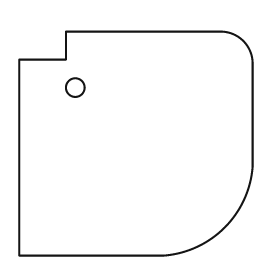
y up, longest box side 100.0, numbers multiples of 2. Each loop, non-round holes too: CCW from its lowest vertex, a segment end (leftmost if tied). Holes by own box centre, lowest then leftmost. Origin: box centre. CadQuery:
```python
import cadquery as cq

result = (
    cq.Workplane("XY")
    .moveTo(-50.0, -48.0)
    .lineTo(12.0, -48.0)
    .threePointArc((38.0, -36.0), (50.0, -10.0))
    .lineTo(50.0, 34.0)
    .threePointArc((46.0, 44.0), (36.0, 48.0))
    .lineTo(-30.0, 48.0)
    .lineTo(-30.0, 36.0)
    .lineTo(-50.0, 36.0)
    .close()
    .moveTo(-26.0, 24.0)
    .circle(4.0)
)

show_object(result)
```